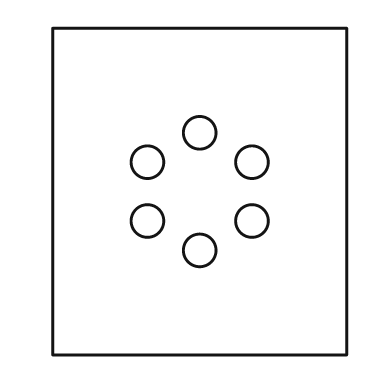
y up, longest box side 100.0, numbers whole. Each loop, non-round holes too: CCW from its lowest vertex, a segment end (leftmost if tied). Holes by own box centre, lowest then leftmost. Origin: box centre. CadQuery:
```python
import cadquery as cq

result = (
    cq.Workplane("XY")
    .moveTo(-45.0, -50.0)
    .lineTo(45.0, -50.0)
    .lineTo(45.0, 50.0)
    .lineTo(-45.0, 50.0)
    .close()
    .moveTo(0.0, -18.0)
    .circle(5.0)
    .moveTo(-16.0, -9.0)
    .circle(5.0)
    .moveTo(16.0, -9.0)
    .circle(5.0)
    .moveTo(-16.0, 9.0)
    .circle(5.0)
    .moveTo(16.0, 9.0)
    .circle(5.0)
    .moveTo(0.0, 18.0)
    .circle(5.0)
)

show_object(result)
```